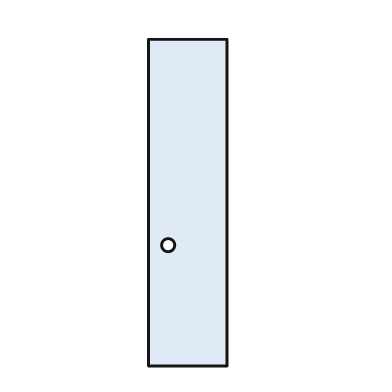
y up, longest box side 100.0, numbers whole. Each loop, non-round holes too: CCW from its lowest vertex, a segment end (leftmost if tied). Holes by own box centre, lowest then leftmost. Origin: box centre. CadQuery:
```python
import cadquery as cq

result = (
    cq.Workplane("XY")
    .moveTo(-12.0, -50.0)
    .lineTo(12.0, -50.0)
    .lineTo(12.0, 50.0)
    .lineTo(-12.0, 50.0)
    .close()
    .moveTo(-6.0, -13.0)
    .circle(2.0)
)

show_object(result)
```